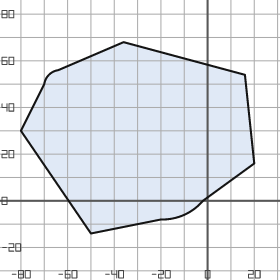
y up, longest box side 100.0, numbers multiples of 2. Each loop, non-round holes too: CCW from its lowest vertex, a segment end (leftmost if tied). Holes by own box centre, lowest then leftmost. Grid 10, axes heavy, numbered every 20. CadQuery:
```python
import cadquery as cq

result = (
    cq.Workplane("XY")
    .moveTo(-50.0, -14.0)
    .lineTo(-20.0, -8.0)
    .threePointArc((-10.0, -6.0), (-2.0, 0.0))
    .lineTo(20.0, 16.0)
    .lineTo(16.0, 54.0)
    .lineTo(-36.0, 68.0)
    .lineTo(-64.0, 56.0)
    .threePointArc((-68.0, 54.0), (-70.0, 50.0))
    .lineTo(-80.0, 30.0)
    .close()
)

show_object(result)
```